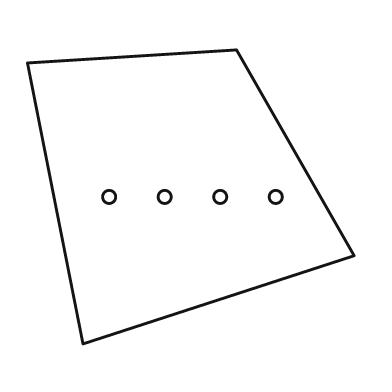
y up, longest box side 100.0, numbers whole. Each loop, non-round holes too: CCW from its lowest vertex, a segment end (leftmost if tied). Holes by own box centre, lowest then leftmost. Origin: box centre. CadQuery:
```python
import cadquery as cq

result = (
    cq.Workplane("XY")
    .moveTo(-33.0, -45.0)
    .lineTo(50.0, -18.0)
    .lineTo(14.0, 45.0)
    .lineTo(-50.0, 41.0)
    .close()
    .moveTo(-25.0, 0.0)
    .circle(2.0)
    .moveTo(-8.0, 0.0)
    .circle(2.0)
    .moveTo(9.0, 0.0)
    .circle(2.0)
    .moveTo(26.0, 0.0)
    .circle(2.0)
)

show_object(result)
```